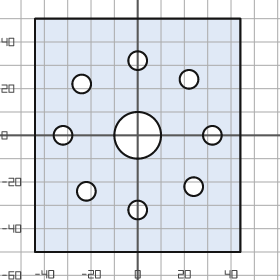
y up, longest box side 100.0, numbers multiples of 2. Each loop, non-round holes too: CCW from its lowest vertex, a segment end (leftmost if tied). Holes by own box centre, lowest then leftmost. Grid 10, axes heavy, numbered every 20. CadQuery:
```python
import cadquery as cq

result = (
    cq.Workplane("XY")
    .moveTo(-44.0, -50.0)
    .lineTo(44.0, -50.0)
    .lineTo(44.0, 50.0)
    .lineTo(-44.0, 50.0)
    .close()
    .moveTo(0.0, -32.0)
    .circle(4.0)
    .moveTo(-22.0, -24.0)
    .circle(4.0)
    .moveTo(24.0, -22.0)
    .circle(4.0)
    .moveTo(-32.0, 0.0)
    .circle(4.0)
    .moveTo(0.0, 0.0)
    .circle(10.0)
    .moveTo(32.0, 0.0)
    .circle(4.0)
    .moveTo(-24.0, 22.0)
    .circle(4.0)
    .moveTo(22.0, 24.0)
    .circle(4.0)
    .moveTo(0.0, 32.0)
    .circle(4.0)
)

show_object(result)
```